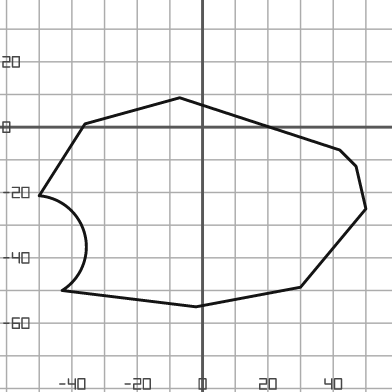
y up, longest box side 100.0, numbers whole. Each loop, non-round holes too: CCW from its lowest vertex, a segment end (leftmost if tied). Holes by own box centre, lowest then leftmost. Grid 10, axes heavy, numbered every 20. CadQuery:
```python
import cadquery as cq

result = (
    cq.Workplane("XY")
    .moveTo(-2.0, -55.0)
    .lineTo(30.0, -49.0)
    .lineTo(50.0, -25.0)
    .lineTo(47.0, -12.0)
    .lineTo(42.0, -7.0)
    .lineTo(-7.0, 9.0)
    .lineTo(-36.0, 1.0)
    .lineTo(-50.0, -21.0)
    .threePointArc((-36.0, -33.0), (-43.0, -50.0))
    .close()
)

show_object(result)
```